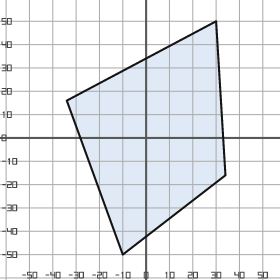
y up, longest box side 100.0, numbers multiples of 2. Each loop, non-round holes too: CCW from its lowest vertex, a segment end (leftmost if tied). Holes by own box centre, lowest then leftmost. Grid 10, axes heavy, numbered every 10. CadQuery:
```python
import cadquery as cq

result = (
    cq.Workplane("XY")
    .moveTo(-10.0, -50.0)
    .lineTo(34.0, -16.0)
    .lineTo(30.0, 50.0)
    .lineTo(-34.0, 16.0)
    .close()
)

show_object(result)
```